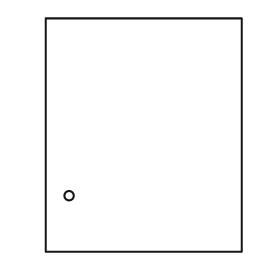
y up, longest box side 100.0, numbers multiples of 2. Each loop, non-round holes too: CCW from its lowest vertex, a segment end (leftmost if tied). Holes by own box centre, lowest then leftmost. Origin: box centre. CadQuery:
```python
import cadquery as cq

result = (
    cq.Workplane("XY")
    .moveTo(-42.0, -50.0)
    .lineTo(42.0, -50.0)
    .lineTo(42.0, 50.0)
    .lineTo(-42.0, 50.0)
    .close()
    .moveTo(-32.0, -26.0)
    .circle(2.0)
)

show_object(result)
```